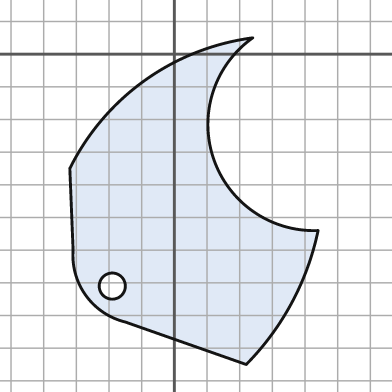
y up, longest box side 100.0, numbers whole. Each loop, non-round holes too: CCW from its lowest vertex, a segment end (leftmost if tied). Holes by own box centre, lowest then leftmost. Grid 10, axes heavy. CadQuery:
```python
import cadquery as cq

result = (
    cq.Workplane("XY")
    .moveTo(22.0, -95.0)
    .threePointArc((36.0, -76.0), (44.0, -54.0))
    .threePointArc((12.0, -32.0), (24.0, 5.0))
    .threePointArc((-9.0, -8.0), (-32.0, -35.0))
    .lineTo(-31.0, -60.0)
    .threePointArc((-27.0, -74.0), (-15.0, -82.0))
    .close()
    .moveTo(-19.0, -71.0)
    .circle(4.0)
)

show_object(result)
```